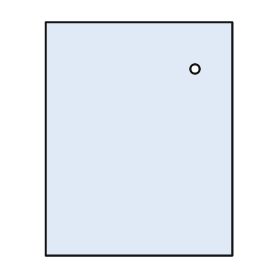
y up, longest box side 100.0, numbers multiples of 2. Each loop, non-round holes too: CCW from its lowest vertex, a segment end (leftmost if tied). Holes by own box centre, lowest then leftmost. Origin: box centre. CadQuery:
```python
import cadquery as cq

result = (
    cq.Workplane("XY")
    .moveTo(-40.0, -50.0)
    .lineTo(40.0, -50.0)
    .lineTo(40.0, 50.0)
    .lineTo(-40.0, 50.0)
    .close()
    .moveTo(24.0, 30.0)
    .circle(2.0)
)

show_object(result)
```